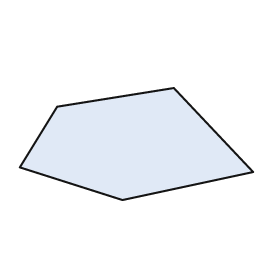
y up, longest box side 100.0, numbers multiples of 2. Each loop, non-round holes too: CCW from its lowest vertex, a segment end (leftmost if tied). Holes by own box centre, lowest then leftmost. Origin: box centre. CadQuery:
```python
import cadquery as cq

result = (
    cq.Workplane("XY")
    .moveTo(-6.0, -24.0)
    .lineTo(50.0, -12.0)
    .lineTo(16.0, 24.0)
    .lineTo(-34.0, 16.0)
    .lineTo(-50.0, -10.0)
    .close()
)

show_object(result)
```